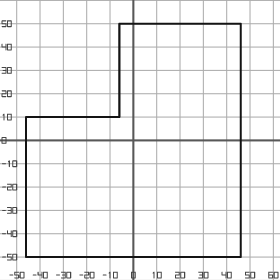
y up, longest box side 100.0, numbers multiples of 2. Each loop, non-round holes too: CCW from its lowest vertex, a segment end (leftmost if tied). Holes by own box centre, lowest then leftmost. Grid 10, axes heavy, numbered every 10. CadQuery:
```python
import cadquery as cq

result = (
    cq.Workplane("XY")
    .moveTo(-46.0, -50.0)
    .lineTo(46.0, -50.0)
    .lineTo(46.0, 50.0)
    .lineTo(-6.0, 50.0)
    .lineTo(-6.0, 10.0)
    .lineTo(-46.0, 10.0)
    .close()
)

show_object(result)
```